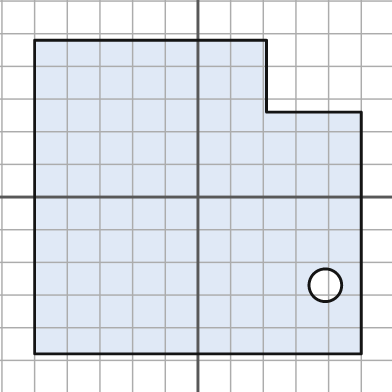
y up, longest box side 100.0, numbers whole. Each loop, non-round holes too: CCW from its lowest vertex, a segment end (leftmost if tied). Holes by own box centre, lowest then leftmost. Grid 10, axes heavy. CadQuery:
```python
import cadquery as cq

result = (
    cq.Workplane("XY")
    .moveTo(-50.0, -48.0)
    .lineTo(50.0, -48.0)
    .lineTo(50.0, 26.0)
    .lineTo(21.0, 26.0)
    .lineTo(21.0, 48.0)
    .lineTo(-50.0, 48.0)
    .close()
    .moveTo(39.0, -27.0)
    .circle(5.0)
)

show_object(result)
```